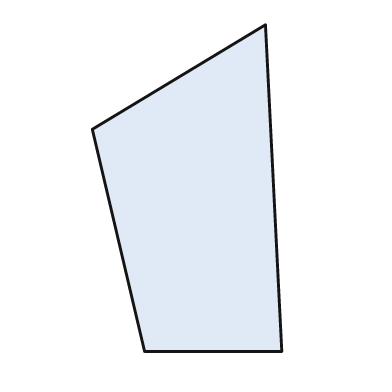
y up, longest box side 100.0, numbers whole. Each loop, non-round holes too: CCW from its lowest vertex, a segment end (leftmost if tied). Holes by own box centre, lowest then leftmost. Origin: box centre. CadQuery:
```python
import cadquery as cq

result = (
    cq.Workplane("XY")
    .moveTo(-13.0, -50.0)
    .lineTo(29.0, -50.0)
    .lineTo(24.0, 50.0)
    .lineTo(-29.0, 18.0)
    .close()
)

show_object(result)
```